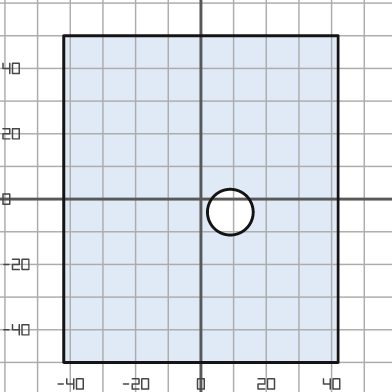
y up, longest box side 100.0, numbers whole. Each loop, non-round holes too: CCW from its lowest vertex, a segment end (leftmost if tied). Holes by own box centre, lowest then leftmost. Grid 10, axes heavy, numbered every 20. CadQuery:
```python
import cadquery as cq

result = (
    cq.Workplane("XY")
    .moveTo(-42.0, -50.0)
    .lineTo(42.0, -50.0)
    .lineTo(42.0, 50.0)
    .lineTo(-42.0, 50.0)
    .close()
    .moveTo(9.0, -4.0)
    .circle(7.0)
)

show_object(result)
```